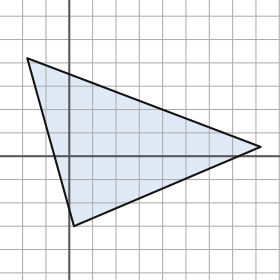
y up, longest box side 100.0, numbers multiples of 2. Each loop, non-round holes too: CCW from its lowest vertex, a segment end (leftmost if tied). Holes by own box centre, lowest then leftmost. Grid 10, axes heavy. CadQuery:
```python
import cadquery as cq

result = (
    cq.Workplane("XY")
    .moveTo(2.0, -30.0)
    .lineTo(82.0, 4.0)
    .lineTo(-18.0, 42.0)
    .close()
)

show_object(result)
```